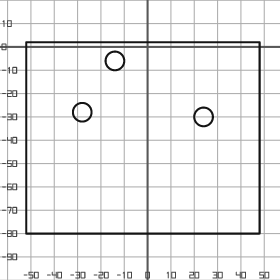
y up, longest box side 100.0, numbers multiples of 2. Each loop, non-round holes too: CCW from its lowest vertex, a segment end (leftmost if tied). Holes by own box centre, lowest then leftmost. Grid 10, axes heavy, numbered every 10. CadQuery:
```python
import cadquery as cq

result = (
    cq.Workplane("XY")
    .moveTo(-52.0, -80.0)
    .lineTo(48.0, -80.0)
    .lineTo(48.0, 2.0)
    .lineTo(-52.0, 2.0)
    .close()
    .moveTo(24.0, -30.0)
    .circle(4.0)
    .moveTo(-28.0, -28.0)
    .circle(4.0)
    .moveTo(-14.0, -6.0)
    .circle(4.0)
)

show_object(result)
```